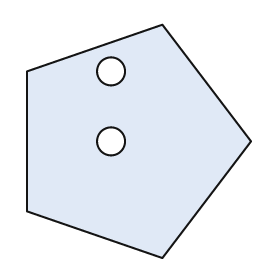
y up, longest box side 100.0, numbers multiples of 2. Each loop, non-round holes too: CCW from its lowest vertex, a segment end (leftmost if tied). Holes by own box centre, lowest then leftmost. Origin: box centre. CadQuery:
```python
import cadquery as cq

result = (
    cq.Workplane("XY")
    .moveTo(10.0, -50.0)
    .lineTo(48.0, 0.0)
    .lineTo(10.0, 50.0)
    .lineTo(-48.0, 30.0)
    .lineTo(-48.0, -30.0)
    .close()
    .moveTo(-12.0, 0.0)
    .circle(6.0)
    .moveTo(-12.0, 30.0)
    .circle(6.0)
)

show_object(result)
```